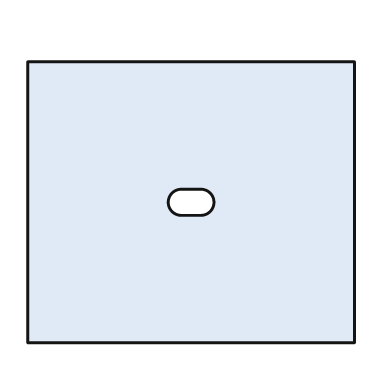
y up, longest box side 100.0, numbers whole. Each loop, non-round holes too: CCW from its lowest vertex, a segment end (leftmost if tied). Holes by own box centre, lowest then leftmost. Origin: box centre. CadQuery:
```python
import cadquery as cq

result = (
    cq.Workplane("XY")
    .moveTo(-50.0, -43.0)
    .lineTo(50.0, -43.0)
    .lineTo(50.0, 43.0)
    .lineTo(-50.0, 43.0)
    .close()
    .moveTo(-3.0, -4.0)
    .lineTo(3.0, -4.0)
    .threePointArc((7.0, 0.0), (3.0, 4.0))
    .lineTo(-3.0, 4.0)
    .threePointArc((-7.0, 0.0), (-3.0, -4.0))
    .close()
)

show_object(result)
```